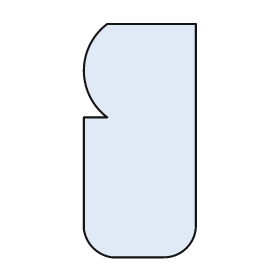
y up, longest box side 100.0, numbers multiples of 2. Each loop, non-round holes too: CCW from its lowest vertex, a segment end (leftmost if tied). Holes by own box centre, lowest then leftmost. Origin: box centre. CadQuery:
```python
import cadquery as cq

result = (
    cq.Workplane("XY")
    .moveTo(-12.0, -50.0)
    .lineTo(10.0, -50.0)
    .threePointArc((20.0, -46.0), (24.0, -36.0))
    .lineTo(24.0, 50.0)
    .lineTo(-14.0, 50.0)
    .threePointArc((-24.0, 30.0), (-14.0, 10.0))
    .lineTo(-24.0, 10.0)
    .lineTo(-24.0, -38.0)
    .threePointArc((-20.0, -46.0), (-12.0, -50.0))
    .close()
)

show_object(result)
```